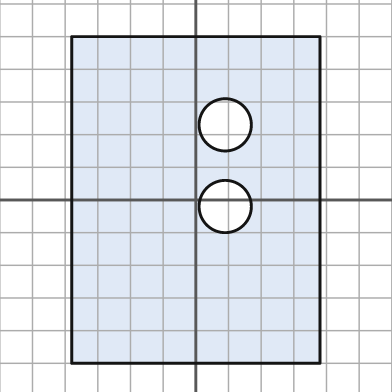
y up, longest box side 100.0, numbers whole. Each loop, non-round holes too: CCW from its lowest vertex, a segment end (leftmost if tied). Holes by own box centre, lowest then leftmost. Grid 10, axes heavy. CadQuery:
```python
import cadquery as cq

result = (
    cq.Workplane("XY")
    .moveTo(-38.0, -50.0)
    .lineTo(38.0, -50.0)
    .lineTo(38.0, 50.0)
    .lineTo(-38.0, 50.0)
    .close()
    .moveTo(9.0, -2.0)
    .circle(8.0)
    .moveTo(9.0, 23.0)
    .circle(8.0)
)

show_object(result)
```